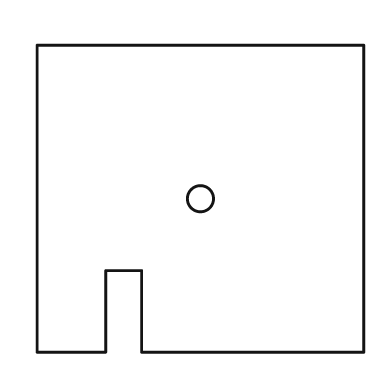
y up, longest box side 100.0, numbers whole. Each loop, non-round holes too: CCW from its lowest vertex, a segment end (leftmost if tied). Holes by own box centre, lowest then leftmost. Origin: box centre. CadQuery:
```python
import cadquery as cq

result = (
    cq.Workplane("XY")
    .moveTo(-50.0, -47.0)
    .lineTo(-29.0, -47.0)
    .lineTo(-29.0, -22.0)
    .lineTo(-18.0, -22.0)
    .lineTo(-18.0, -47.0)
    .lineTo(50.0, -47.0)
    .lineTo(50.0, 47.0)
    .lineTo(-50.0, 47.0)
    .close()
    .moveTo(0.0, 0.0)
    .circle(4.0)
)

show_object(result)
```